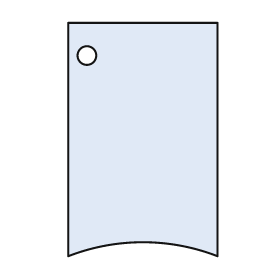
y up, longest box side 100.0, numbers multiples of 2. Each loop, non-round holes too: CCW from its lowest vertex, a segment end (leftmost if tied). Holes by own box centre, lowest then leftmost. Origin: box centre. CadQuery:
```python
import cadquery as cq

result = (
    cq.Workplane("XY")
    .moveTo(-32.0, -50.0)
    .threePointArc((0.0, -44.0), (32.0, -50.0))
    .lineTo(32.0, 50.0)
    .lineTo(-32.0, 50.0)
    .close()
    .moveTo(-24.0, 36.0)
    .circle(4.0)
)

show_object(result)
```